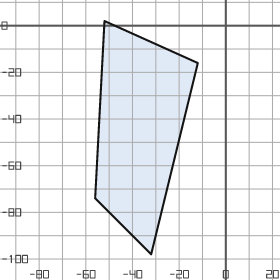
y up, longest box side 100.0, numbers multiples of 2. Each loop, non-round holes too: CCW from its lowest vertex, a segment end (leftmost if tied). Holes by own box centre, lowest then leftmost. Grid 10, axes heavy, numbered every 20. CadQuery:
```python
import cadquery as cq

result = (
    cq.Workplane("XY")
    .moveTo(-32.0, -98.0)
    .lineTo(-12.0, -16.0)
    .lineTo(-52.0, 2.0)
    .lineTo(-56.0, -74.0)
    .close()
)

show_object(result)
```